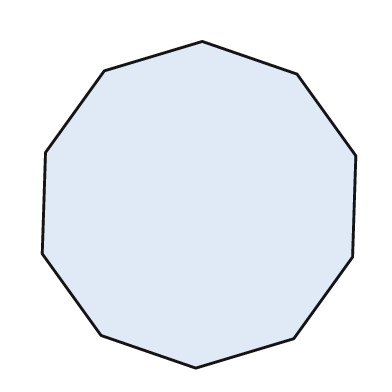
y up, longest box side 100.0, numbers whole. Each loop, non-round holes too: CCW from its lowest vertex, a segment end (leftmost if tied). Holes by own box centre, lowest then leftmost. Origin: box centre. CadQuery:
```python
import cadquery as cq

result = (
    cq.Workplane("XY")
    .moveTo(-1.0, -50.0)
    .lineTo(29.0, -41.0)
    .lineTo(47.0, -16.0)
    .lineTo(48.0, 15.0)
    .lineTo(30.0, 40.0)
    .lineTo(1.0, 50.0)
    .lineTo(-29.0, 41.0)
    .lineTo(-47.0, 16.0)
    .lineTo(-48.0, -15.0)
    .lineTo(-30.0, -40.0)
    .close()
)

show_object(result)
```